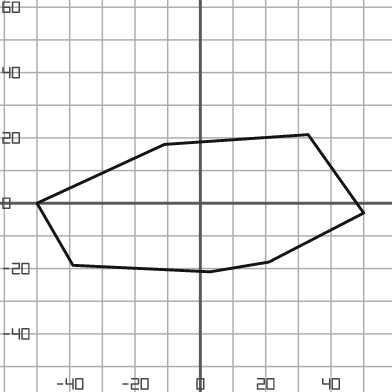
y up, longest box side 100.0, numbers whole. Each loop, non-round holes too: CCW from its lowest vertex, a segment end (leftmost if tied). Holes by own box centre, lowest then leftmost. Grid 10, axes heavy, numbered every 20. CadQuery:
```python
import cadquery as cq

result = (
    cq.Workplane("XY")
    .moveTo(3.0, -21.0)
    .lineTo(21.0, -18.0)
    .lineTo(50.0, -3.0)
    .lineTo(33.0, 21.0)
    .lineTo(-11.0, 18.0)
    .lineTo(-50.0, 0.0)
    .lineTo(-39.0, -19.0)
    .close()
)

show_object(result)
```